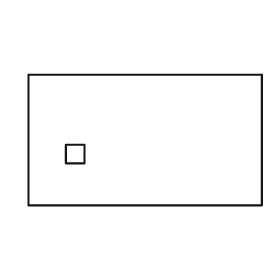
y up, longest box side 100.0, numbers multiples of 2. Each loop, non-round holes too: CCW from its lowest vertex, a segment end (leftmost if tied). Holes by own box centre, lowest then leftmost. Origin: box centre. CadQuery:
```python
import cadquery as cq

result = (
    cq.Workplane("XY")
    .moveTo(-50.0, -28.0)
    .lineTo(50.0, -28.0)
    .lineTo(50.0, 28.0)
    .lineTo(-50.0, 28.0)
    .close()
    .moveTo(-34.0, -10.0)
    .lineTo(-26.0, -10.0)
    .lineTo(-26.0, -2.0)
    .lineTo(-34.0, -2.0)
    .close()
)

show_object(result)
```